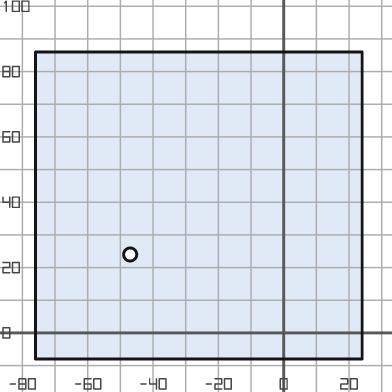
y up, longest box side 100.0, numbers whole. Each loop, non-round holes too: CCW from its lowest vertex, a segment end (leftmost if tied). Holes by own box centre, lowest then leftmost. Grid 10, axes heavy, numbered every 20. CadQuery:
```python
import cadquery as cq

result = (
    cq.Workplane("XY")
    .moveTo(-76.0, -8.0)
    .lineTo(24.0, -8.0)
    .lineTo(24.0, 86.0)
    .lineTo(-76.0, 86.0)
    .close()
    .moveTo(-47.0, 24.0)
    .circle(2.0)
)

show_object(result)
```